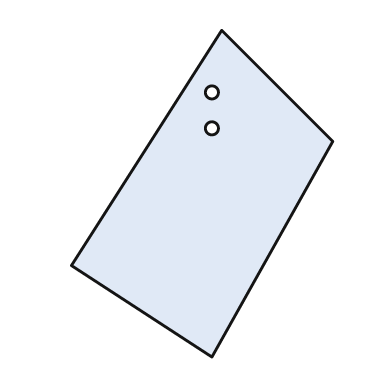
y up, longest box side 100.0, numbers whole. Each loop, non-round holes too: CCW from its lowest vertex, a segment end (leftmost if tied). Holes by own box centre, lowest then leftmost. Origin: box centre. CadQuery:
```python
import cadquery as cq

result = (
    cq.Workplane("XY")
    .moveTo(3.0, -50.0)
    .lineTo(40.0, 16.0)
    .lineTo(6.0, 50.0)
    .lineTo(-40.0, -22.0)
    .close()
    .moveTo(3.0, 20.0)
    .circle(2.0)
    .moveTo(3.0, 31.0)
    .circle(2.0)
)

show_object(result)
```